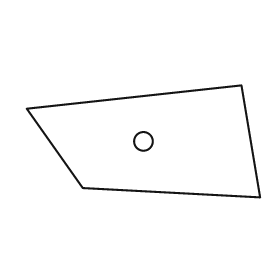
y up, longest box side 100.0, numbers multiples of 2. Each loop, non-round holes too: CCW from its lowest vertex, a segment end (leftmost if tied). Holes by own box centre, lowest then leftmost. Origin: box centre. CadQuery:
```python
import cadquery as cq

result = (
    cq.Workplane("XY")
    .moveTo(50.0, -24.0)
    .lineTo(42.0, 24.0)
    .lineTo(-50.0, 14.0)
    .lineTo(-26.0, -20.0)
    .close()
    .moveTo(0.0, 0.0)
    .circle(4.0)
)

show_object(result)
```